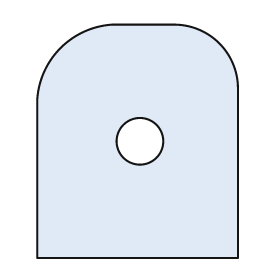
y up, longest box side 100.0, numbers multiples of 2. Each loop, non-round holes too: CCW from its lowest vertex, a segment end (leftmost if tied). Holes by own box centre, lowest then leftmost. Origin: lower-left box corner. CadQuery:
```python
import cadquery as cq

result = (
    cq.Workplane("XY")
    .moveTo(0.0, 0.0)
    .lineTo(86.0, 0.0)
    .lineTo(86.0, 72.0)
    .threePointArc((78.0, 92.0), (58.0, 100.0))
    .lineTo(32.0, 100.0)
    .threePointArc((10.0, 90.0), (0.0, 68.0))
    .close()
    .moveTo(44.0, 50.0)
    .circle(10.0)
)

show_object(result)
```